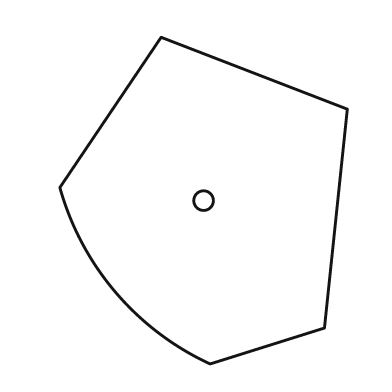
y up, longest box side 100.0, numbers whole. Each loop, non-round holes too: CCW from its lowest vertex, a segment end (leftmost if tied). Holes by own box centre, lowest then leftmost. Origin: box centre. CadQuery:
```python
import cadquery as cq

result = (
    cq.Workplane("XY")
    .moveTo(2.0, -50.0)
    .lineTo(37.0, -39.0)
    .lineTo(44.0, 28.0)
    .lineTo(-13.0, 50.0)
    .lineTo(-44.0, 4.0)
    .threePointArc((-27.0, -28.0), (2.0, -50.0))
    .close()
    .moveTo(0.0, 0.0)
    .circle(3.0)
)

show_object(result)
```